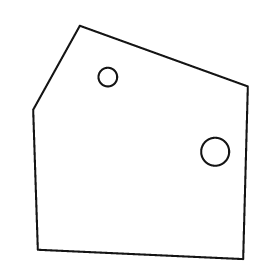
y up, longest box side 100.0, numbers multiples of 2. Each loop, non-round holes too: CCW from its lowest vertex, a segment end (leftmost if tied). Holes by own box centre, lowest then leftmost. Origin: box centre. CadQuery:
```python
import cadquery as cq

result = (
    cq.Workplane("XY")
    .moveTo(44.0, -50.0)
    .lineTo(46.0, 24.0)
    .lineTo(-26.0, 50.0)
    .lineTo(-46.0, 14.0)
    .lineTo(-44.0, -46.0)
    .close()
    .moveTo(32.0, -4.0)
    .circle(6.0)
    .moveTo(-14.0, 28.0)
    .circle(4.0)
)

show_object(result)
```